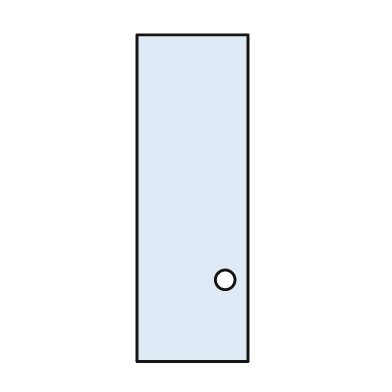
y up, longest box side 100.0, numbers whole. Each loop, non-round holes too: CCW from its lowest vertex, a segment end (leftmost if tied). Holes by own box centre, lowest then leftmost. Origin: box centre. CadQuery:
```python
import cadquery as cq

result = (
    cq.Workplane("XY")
    .moveTo(-17.0, -50.0)
    .lineTo(17.0, -50.0)
    .lineTo(17.0, 50.0)
    .lineTo(-17.0, 50.0)
    .close()
    .moveTo(10.0, -25.0)
    .circle(3.0)
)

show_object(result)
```